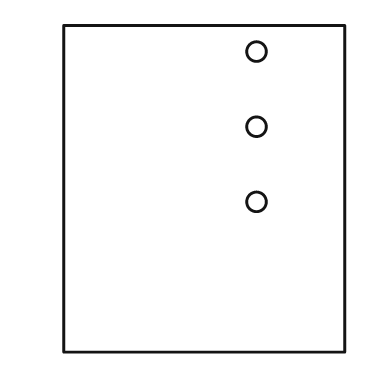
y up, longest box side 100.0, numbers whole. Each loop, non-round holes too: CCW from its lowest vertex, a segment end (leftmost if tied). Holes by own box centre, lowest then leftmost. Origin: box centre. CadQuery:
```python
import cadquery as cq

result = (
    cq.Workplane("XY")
    .moveTo(-43.0, -50.0)
    .lineTo(43.0, -50.0)
    .lineTo(43.0, 50.0)
    .lineTo(-43.0, 50.0)
    .close()
    .moveTo(16.0, -4.0)
    .circle(3.0)
    .moveTo(16.0, 19.0)
    .circle(3.0)
    .moveTo(16.0, 42.0)
    .circle(3.0)
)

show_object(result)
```